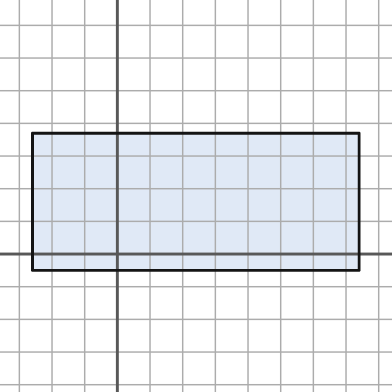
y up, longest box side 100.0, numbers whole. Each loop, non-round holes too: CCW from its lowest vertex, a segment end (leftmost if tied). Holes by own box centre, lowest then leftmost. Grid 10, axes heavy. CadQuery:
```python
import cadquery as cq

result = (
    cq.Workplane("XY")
    .moveTo(-26.0, -5.0)
    .lineTo(74.0, -5.0)
    .lineTo(74.0, 37.0)
    .lineTo(-26.0, 37.0)
    .close()
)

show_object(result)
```